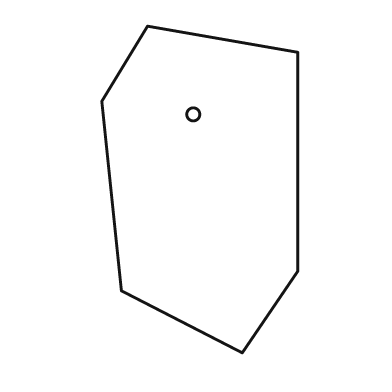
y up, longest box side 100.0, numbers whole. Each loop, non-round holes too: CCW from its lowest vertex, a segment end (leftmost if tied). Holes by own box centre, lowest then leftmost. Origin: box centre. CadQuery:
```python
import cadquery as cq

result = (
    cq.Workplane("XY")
    .moveTo(13.0, -50.0)
    .lineTo(30.0, -25.0)
    .lineTo(30.0, 42.0)
    .lineTo(-16.0, 50.0)
    .lineTo(-30.0, 27.0)
    .lineTo(-24.0, -31.0)
    .close()
    .moveTo(-2.0, 23.0)
    .circle(2.0)
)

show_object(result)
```